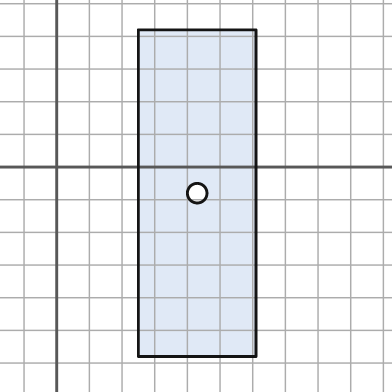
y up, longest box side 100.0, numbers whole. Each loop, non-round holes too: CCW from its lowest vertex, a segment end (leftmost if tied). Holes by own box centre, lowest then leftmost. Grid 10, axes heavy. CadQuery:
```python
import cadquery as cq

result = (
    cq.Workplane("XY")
    .moveTo(25.0, -58.0)
    .lineTo(61.0, -58.0)
    .lineTo(61.0, 42.0)
    .lineTo(25.0, 42.0)
    .close()
    .moveTo(43.0, -8.0)
    .circle(3.0)
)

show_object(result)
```